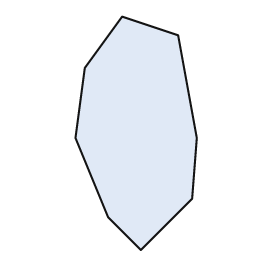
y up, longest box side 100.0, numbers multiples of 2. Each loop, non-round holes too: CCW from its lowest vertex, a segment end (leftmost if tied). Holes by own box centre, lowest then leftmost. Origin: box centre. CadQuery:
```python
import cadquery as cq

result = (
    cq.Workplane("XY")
    .moveTo(2.0, -50.0)
    .lineTo(24.0, -28.0)
    .lineTo(26.0, -2.0)
    .lineTo(18.0, 42.0)
    .lineTo(-6.0, 50.0)
    .lineTo(-22.0, 28.0)
    .lineTo(-26.0, -2.0)
    .lineTo(-12.0, -36.0)
    .close()
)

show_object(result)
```